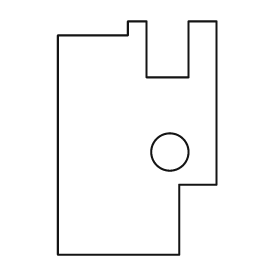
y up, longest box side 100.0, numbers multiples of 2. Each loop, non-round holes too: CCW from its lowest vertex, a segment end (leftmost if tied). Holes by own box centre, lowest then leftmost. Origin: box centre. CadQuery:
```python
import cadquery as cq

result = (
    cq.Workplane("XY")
    .moveTo(-34.0, -50.0)
    .lineTo(18.0, -50.0)
    .lineTo(18.0, -20.0)
    .lineTo(34.0, -20.0)
    .lineTo(34.0, 50.0)
    .lineTo(22.0, 50.0)
    .lineTo(22.0, 26.0)
    .lineTo(4.0, 26.0)
    .lineTo(4.0, 50.0)
    .lineTo(-4.0, 50.0)
    .lineTo(-4.0, 44.0)
    .lineTo(-34.0, 44.0)
    .close()
    .moveTo(14.0, -6.0)
    .circle(8.0)
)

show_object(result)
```